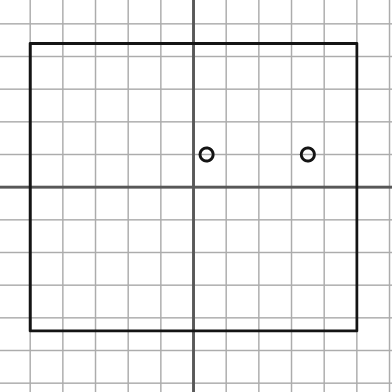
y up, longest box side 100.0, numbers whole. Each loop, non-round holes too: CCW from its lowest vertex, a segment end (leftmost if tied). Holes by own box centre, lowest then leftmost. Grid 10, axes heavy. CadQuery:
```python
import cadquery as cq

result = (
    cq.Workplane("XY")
    .moveTo(-50.0, -44.0)
    .lineTo(50.0, -44.0)
    .lineTo(50.0, 44.0)
    .lineTo(-50.0, 44.0)
    .close()
    .moveTo(4.0, 10.0)
    .circle(2.0)
    .moveTo(35.0, 10.0)
    .circle(2.0)
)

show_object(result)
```